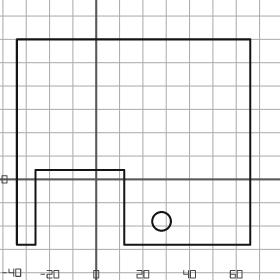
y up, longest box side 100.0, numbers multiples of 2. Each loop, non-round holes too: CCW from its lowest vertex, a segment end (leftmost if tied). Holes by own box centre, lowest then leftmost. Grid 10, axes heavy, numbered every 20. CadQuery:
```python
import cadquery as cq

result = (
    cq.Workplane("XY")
    .moveTo(-34.0, -28.0)
    .lineTo(-26.0, -28.0)
    .lineTo(-26.0, 4.0)
    .lineTo(12.0, 4.0)
    .lineTo(12.0, -28.0)
    .lineTo(66.0, -28.0)
    .lineTo(66.0, 60.0)
    .lineTo(-34.0, 60.0)
    .close()
    .moveTo(28.0, -18.0)
    .circle(4.0)
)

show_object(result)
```